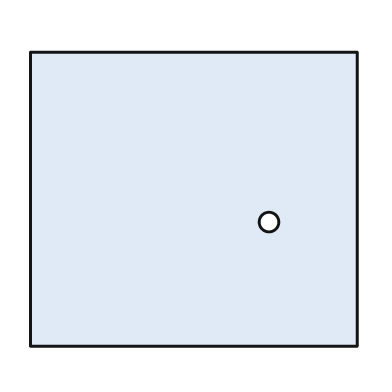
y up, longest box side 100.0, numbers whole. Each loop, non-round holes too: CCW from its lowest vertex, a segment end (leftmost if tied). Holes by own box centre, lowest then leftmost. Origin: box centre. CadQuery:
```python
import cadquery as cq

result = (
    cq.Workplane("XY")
    .moveTo(-50.0, -45.0)
    .lineTo(50.0, -45.0)
    .lineTo(50.0, 45.0)
    .lineTo(-50.0, 45.0)
    .close()
    .moveTo(23.0, -7.0)
    .circle(3.0)
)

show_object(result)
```